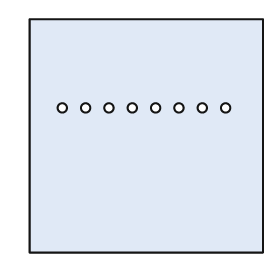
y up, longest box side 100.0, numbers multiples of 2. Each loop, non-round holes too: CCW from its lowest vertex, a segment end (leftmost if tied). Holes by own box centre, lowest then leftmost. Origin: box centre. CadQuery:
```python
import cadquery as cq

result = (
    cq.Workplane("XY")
    .moveTo(-50.0, -50.0)
    .lineTo(50.0, -50.0)
    .lineTo(50.0, 50.0)
    .lineTo(-50.0, 50.0)
    .close()
    .moveTo(-36.0, 12.0)
    .circle(2.0)
    .moveTo(-26.0, 12.0)
    .circle(2.0)
    .moveTo(-16.0, 12.0)
    .circle(2.0)
    .moveTo(-6.0, 12.0)
    .circle(2.0)
    .moveTo(4.0, 12.0)
    .circle(2.0)
    .moveTo(14.0, 12.0)
    .circle(2.0)
    .moveTo(24.0, 12.0)
    .circle(2.0)
    .moveTo(34.0, 12.0)
    .circle(2.0)
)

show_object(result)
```